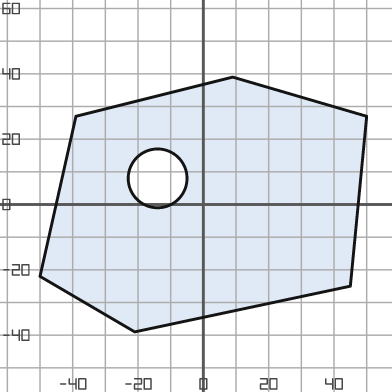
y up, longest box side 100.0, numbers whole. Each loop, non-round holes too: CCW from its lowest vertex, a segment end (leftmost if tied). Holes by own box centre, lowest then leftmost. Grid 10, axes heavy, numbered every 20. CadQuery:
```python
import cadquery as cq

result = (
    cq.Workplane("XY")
    .moveTo(-21.0, -39.0)
    .lineTo(45.0, -25.0)
    .lineTo(50.0, 27.0)
    .lineTo(9.0, 39.0)
    .lineTo(-39.0, 27.0)
    .lineTo(-50.0, -22.0)
    .close()
    .moveTo(-14.0, 8.0)
    .circle(9.0)
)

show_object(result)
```